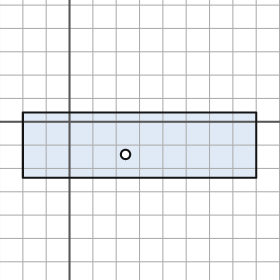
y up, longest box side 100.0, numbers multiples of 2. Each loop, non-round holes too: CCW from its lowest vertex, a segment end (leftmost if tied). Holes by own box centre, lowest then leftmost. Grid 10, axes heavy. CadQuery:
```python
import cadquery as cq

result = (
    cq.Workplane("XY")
    .moveTo(-20.0, -24.0)
    .lineTo(80.0, -24.0)
    .lineTo(80.0, 4.0)
    .lineTo(-20.0, 4.0)
    .close()
    .moveTo(24.0, -14.0)
    .circle(2.0)
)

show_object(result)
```